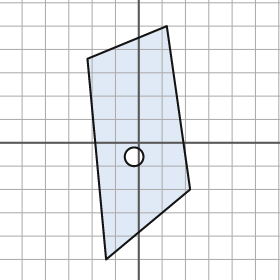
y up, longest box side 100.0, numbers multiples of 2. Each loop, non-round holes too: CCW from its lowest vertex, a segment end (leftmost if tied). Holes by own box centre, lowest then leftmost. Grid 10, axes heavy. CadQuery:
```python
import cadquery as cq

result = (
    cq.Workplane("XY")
    .moveTo(-14.0, -50.0)
    .lineTo(22.0, -20.0)
    .lineTo(12.0, 50.0)
    .lineTo(-22.0, 36.0)
    .close()
    .moveTo(-2.0, -6.0)
    .circle(4.0)
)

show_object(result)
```